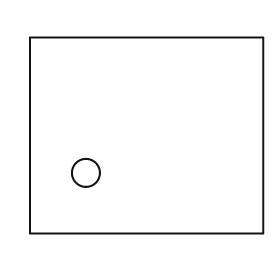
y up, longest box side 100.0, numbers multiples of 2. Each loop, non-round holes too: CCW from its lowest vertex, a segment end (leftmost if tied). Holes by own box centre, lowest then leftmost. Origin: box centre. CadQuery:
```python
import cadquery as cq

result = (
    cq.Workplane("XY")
    .moveTo(-50.0, -42.0)
    .lineTo(50.0, -42.0)
    .lineTo(50.0, 42.0)
    .lineTo(-50.0, 42.0)
    .close()
    .moveTo(-26.0, -16.0)
    .circle(6.0)
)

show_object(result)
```